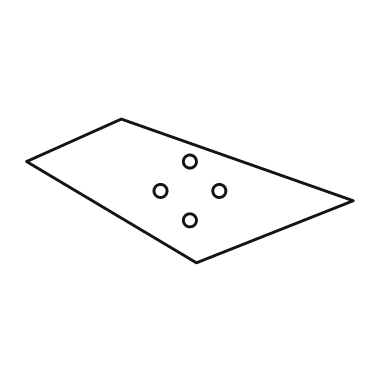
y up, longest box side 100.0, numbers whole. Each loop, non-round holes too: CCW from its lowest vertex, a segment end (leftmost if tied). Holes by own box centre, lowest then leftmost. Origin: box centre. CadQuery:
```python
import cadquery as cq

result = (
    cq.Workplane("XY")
    .moveTo(2.0, -22.0)
    .lineTo(50.0, -3.0)
    .lineTo(-21.0, 22.0)
    .lineTo(-50.0, 9.0)
    .close()
    .moveTo(0.0, -9.0)
    .circle(2.0)
    .moveTo(-9.0, 0.0)
    .circle(2.0)
    .moveTo(9.0, 0.0)
    .circle(2.0)
    .moveTo(0.0, 9.0)
    .circle(2.0)
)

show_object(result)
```